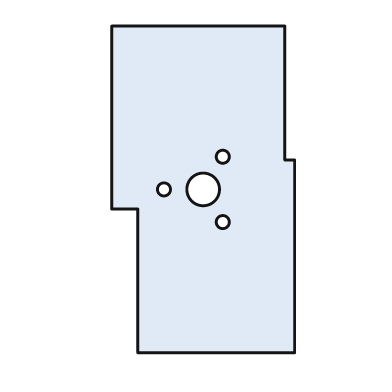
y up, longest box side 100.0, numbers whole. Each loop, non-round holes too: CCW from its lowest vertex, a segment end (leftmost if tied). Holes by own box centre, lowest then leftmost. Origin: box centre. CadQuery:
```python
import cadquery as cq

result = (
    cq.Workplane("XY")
    .moveTo(-20.0, -50.0)
    .lineTo(28.0, -50.0)
    .lineTo(28.0, 9.0)
    .lineTo(25.0, 9.0)
    .lineTo(25.0, 50.0)
    .lineTo(-28.0, 50.0)
    .lineTo(-28.0, -6.0)
    .lineTo(-20.0, -6.0)
    .close()
    .moveTo(6.0, -10.0)
    .circle(2.0)
    .moveTo(-12.0, 0.0)
    .circle(2.0)
    .moveTo(0.0, 0.0)
    .circle(5.0)
    .moveTo(6.0, 10.0)
    .circle(2.0)
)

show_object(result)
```